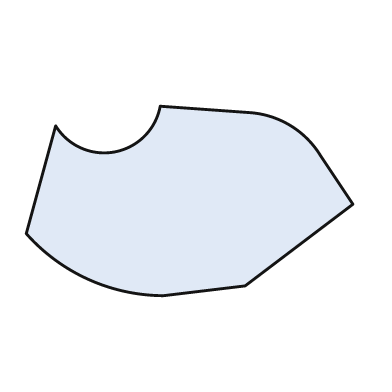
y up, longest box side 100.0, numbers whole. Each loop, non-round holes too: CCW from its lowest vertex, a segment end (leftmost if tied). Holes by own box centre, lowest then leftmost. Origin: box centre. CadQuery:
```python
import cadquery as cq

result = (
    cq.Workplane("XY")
    .moveTo(-8.0, -29.0)
    .lineTo(17.0, -26.0)
    .lineTo(50.0, -1.0)
    .lineTo(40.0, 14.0)
    .threePointArc((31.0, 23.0), (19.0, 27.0))
    .lineTo(-9.0, 29.0)
    .threePointArc((-23.0, 15.0), (-41.0, 23.0))
    .lineTo(-50.0, -10.0)
    .threePointArc((-31.0, -24.0), (-8.0, -29.0))
    .close()
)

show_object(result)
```